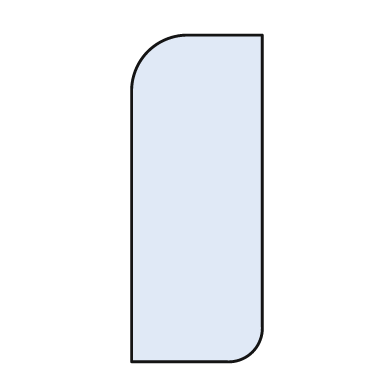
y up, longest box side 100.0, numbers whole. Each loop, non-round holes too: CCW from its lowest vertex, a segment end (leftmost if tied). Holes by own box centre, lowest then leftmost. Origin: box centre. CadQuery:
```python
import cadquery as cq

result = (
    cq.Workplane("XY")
    .moveTo(-20.0, -50.0)
    .lineTo(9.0, -50.0)
    .threePointArc((17.0, -47.0), (20.0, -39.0))
    .lineTo(20.0, 50.0)
    .lineTo(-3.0, 50.0)
    .threePointArc((-15.0, 45.0), (-20.0, 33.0))
    .close()
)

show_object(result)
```